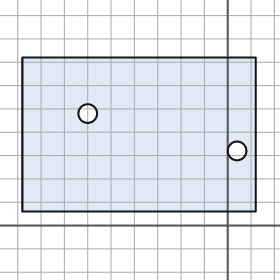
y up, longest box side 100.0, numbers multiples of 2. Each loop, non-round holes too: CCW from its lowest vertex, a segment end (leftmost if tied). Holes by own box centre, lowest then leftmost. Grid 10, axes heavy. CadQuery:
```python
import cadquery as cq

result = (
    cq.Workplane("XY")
    .moveTo(-88.0, 6.0)
    .lineTo(12.0, 6.0)
    .lineTo(12.0, 72.0)
    .lineTo(-88.0, 72.0)
    .close()
    .moveTo(4.0, 32.0)
    .circle(4.0)
    .moveTo(-60.0, 48.0)
    .circle(4.0)
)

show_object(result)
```